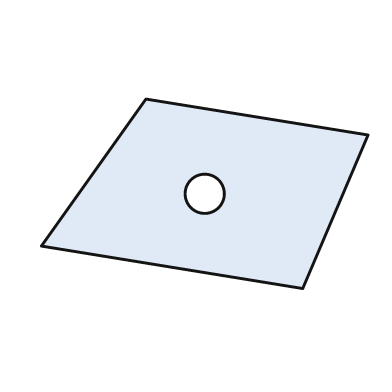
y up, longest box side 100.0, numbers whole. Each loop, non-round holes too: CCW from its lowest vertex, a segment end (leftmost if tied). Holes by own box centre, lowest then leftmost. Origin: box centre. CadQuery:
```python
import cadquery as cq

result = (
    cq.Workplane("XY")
    .moveTo(30.0, -29.0)
    .lineTo(50.0, 18.0)
    .lineTo(-18.0, 29.0)
    .lineTo(-50.0, -16.0)
    .close()
    .moveTo(0.0, 0.0)
    .circle(6.0)
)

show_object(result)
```